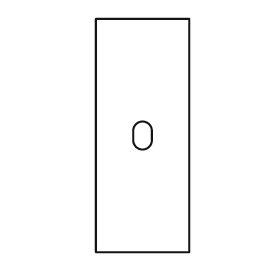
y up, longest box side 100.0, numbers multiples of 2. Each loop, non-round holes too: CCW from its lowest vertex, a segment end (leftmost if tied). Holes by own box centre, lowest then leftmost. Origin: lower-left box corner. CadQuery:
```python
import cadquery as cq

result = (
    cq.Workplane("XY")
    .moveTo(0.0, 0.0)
    .lineTo(40.0, 0.0)
    .lineTo(40.0, 100.0)
    .lineTo(0.0, 100.0)
    .close()
    .moveTo(16.0, 48.0)
    .threePointArc((20.0, 44.0), (24.0, 48.0))
    .lineTo(24.0, 52.0)
    .threePointArc((20.0, 56.0), (16.0, 52.0))
    .close()
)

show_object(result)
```